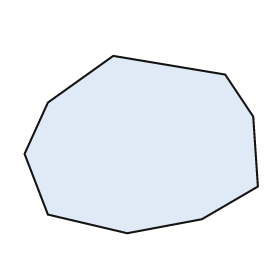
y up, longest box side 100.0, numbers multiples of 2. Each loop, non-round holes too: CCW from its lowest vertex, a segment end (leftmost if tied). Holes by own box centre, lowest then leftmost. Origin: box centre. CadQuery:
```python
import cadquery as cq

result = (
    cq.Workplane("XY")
    .moveTo(-6.0, -38.0)
    .lineTo(26.0, -32.0)
    .lineTo(50.0, -18.0)
    .lineTo(48.0, 12.0)
    .lineTo(36.0, 30.0)
    .lineTo(-12.0, 38.0)
    .lineTo(-40.0, 18.0)
    .lineTo(-50.0, -4.0)
    .lineTo(-40.0, -30.0)
    .close()
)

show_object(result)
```